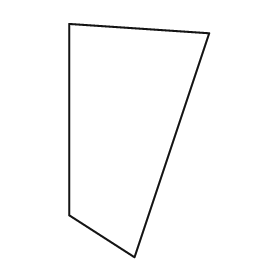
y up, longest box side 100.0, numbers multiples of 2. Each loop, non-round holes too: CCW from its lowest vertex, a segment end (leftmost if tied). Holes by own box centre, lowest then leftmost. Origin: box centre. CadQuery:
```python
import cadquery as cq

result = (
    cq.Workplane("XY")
    .moveTo(-2.0, -50.0)
    .lineTo(30.0, 46.0)
    .lineTo(-30.0, 50.0)
    .lineTo(-30.0, -32.0)
    .close()
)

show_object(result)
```